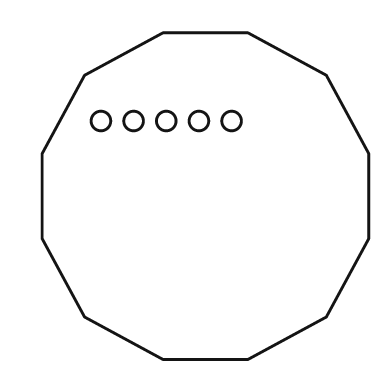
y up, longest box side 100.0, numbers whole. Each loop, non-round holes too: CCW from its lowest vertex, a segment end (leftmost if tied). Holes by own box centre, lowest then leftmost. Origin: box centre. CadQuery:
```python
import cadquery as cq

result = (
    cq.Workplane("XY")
    .moveTo(-13.0, -50.0)
    .lineTo(13.0, -50.0)
    .lineTo(37.0, -37.0)
    .lineTo(50.0, -13.0)
    .lineTo(50.0, 13.0)
    .lineTo(37.0, 37.0)
    .lineTo(13.0, 50.0)
    .lineTo(-13.0, 50.0)
    .lineTo(-37.0, 37.0)
    .lineTo(-50.0, 13.0)
    .lineTo(-50.0, -13.0)
    .lineTo(-37.0, -37.0)
    .close()
    .moveTo(-32.0, 23.0)
    .circle(3.0)
    .moveTo(-22.0, 23.0)
    .circle(3.0)
    .moveTo(-12.0, 23.0)
    .circle(3.0)
    .moveTo(-2.0, 23.0)
    .circle(3.0)
    .moveTo(8.0, 23.0)
    .circle(3.0)
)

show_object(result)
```